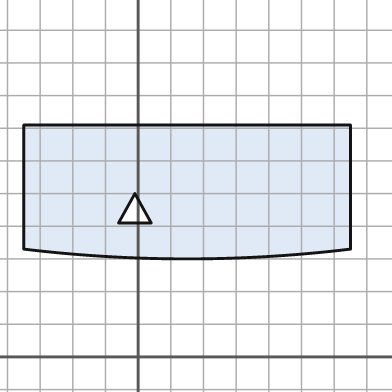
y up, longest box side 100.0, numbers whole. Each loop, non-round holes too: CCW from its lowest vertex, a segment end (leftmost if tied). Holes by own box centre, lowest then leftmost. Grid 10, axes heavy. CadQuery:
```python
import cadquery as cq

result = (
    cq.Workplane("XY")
    .moveTo(-35.0, 33.0)
    .threePointArc((15.0, 30.0), (65.0, 33.0))
    .lineTo(65.0, 71.0)
    .lineTo(-35.0, 71.0)
    .close()
    .moveTo(-6.0, 41.0)
    .lineTo(4.0, 41.0)
    .lineTo(-1.0, 50.0)
    .close()
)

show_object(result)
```